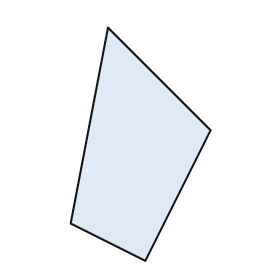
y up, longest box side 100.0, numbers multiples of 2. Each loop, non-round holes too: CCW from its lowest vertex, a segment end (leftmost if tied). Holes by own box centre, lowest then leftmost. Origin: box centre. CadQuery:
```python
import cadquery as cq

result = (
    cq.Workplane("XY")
    .moveTo(2.0, -50.0)
    .lineTo(30.0, 6.0)
    .lineTo(-14.0, 50.0)
    .lineTo(-30.0, -34.0)
    .close()
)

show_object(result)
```